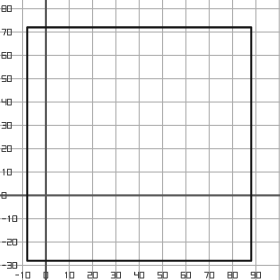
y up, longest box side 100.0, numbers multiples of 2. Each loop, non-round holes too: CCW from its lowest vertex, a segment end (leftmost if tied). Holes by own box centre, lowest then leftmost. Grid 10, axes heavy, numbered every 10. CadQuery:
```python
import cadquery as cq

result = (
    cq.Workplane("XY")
    .moveTo(-8.0, -28.0)
    .lineTo(88.0, -28.0)
    .lineTo(88.0, 72.0)
    .lineTo(-8.0, 72.0)
    .close()
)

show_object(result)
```